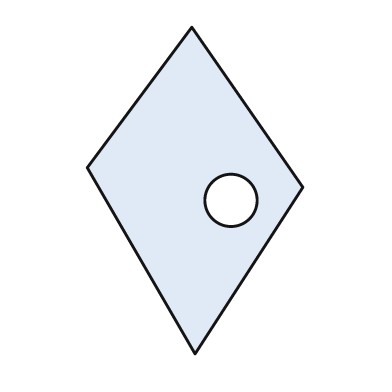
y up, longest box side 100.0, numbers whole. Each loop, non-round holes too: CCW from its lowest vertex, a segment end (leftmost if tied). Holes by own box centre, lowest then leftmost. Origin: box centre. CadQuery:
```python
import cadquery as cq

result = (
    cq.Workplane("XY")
    .moveTo(0.0, -50.0)
    .lineTo(33.0, 1.0)
    .lineTo(-1.0, 50.0)
    .lineTo(-33.0, 7.0)
    .close()
    .moveTo(11.0, -3.0)
    .circle(8.0)
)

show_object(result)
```